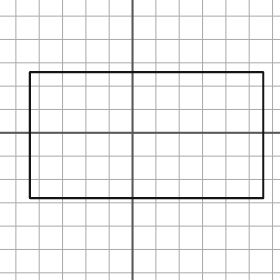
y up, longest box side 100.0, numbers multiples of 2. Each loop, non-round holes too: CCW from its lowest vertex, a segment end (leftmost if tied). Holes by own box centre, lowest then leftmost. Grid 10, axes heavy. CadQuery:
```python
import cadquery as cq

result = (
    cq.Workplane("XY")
    .moveTo(-44.0, -28.0)
    .lineTo(56.0, -28.0)
    .lineTo(56.0, 26.0)
    .lineTo(-44.0, 26.0)
    .close()
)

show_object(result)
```